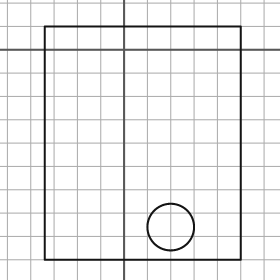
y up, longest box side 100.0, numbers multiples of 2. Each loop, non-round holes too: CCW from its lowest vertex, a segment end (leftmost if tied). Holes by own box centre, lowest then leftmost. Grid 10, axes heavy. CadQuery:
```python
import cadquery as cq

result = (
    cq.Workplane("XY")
    .moveTo(-34.0, -90.0)
    .lineTo(50.0, -90.0)
    .lineTo(50.0, 10.0)
    .lineTo(-34.0, 10.0)
    .close()
    .moveTo(20.0, -76.0)
    .circle(10.0)
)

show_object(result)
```